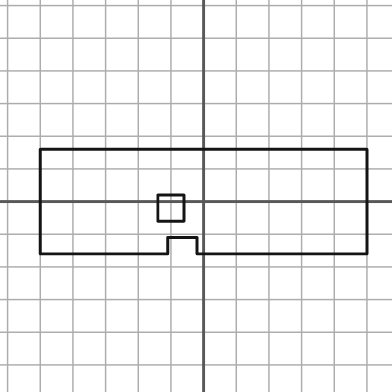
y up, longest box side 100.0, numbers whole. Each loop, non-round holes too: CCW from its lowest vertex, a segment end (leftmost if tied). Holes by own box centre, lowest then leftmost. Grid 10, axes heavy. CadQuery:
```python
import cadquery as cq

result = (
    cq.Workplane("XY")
    .moveTo(-50.0, -16.0)
    .lineTo(-11.0, -16.0)
    .lineTo(-11.0, -11.0)
    .lineTo(-2.0, -11.0)
    .lineTo(-2.0, -16.0)
    .lineTo(50.0, -16.0)
    .lineTo(50.0, 16.0)
    .lineTo(-50.0, 16.0)
    .close()
    .moveTo(-14.0, -6.0)
    .lineTo(-6.0, -6.0)
    .lineTo(-6.0, 2.0)
    .lineTo(-14.0, 2.0)
    .close()
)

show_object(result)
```